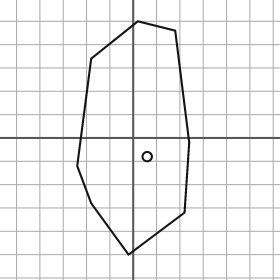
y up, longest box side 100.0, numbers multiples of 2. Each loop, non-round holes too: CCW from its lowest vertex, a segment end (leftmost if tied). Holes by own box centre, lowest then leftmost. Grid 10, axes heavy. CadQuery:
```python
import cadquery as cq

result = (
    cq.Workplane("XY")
    .moveTo(-2.0, -50.0)
    .lineTo(22.0, -32.0)
    .lineTo(24.0, -2.0)
    .lineTo(18.0, 46.0)
    .lineTo(2.0, 50.0)
    .lineTo(-18.0, 34.0)
    .lineTo(-24.0, -12.0)
    .lineTo(-18.0, -28.0)
    .close()
    .moveTo(6.0, -8.0)
    .circle(2.0)
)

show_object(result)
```